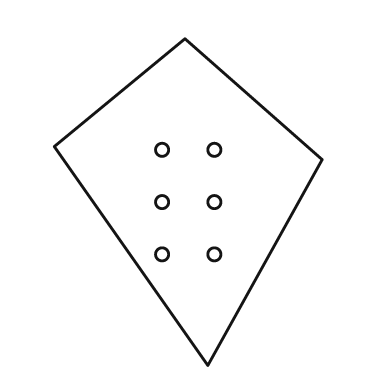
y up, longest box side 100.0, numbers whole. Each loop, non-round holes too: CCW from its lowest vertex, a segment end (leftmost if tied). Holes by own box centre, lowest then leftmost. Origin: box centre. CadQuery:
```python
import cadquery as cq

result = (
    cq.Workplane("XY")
    .moveTo(6.0, -50.0)
    .lineTo(41.0, 13.0)
    .lineTo(-1.0, 50.0)
    .lineTo(-41.0, 17.0)
    .close()
    .moveTo(-8.0, -16.0)
    .circle(2.0)
    .moveTo(8.0, -16.0)
    .circle(2.0)
    .moveTo(-8.0, 0.0)
    .circle(2.0)
    .moveTo(8.0, 0.0)
    .circle(2.0)
    .moveTo(-8.0, 16.0)
    .circle(2.0)
    .moveTo(8.0, 16.0)
    .circle(2.0)
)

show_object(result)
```